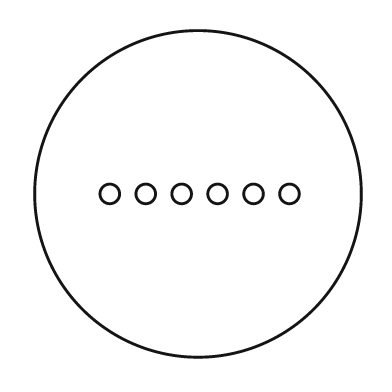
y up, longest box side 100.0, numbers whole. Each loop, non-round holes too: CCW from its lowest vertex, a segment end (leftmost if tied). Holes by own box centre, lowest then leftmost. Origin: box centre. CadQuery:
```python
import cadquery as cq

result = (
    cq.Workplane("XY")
    .moveTo(0.0, 0.0)
    .circle(50.0)
    .moveTo(-27.0, 0.0)
    .circle(3.0)
    .moveTo(-16.0, 0.0)
    .circle(3.0)
    .moveTo(-5.0, 0.0)
    .circle(3.0)
    .moveTo(6.0, 0.0)
    .circle(3.0)
    .moveTo(17.0, 0.0)
    .circle(3.0)
    .moveTo(28.0, 0.0)
    .circle(3.0)
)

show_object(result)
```